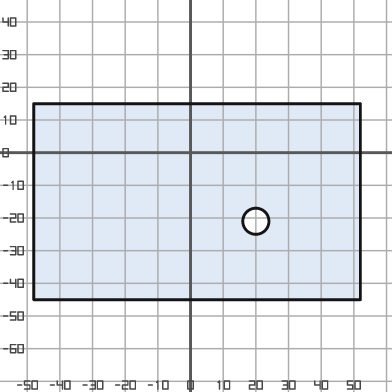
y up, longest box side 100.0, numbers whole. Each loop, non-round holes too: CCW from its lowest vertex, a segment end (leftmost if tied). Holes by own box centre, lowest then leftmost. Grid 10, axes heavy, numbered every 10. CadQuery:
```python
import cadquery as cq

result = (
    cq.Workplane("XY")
    .moveTo(-48.0, -45.0)
    .lineTo(52.0, -45.0)
    .lineTo(52.0, 15.0)
    .lineTo(-48.0, 15.0)
    .close()
    .moveTo(20.0, -21.0)
    .circle(4.0)
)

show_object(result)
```